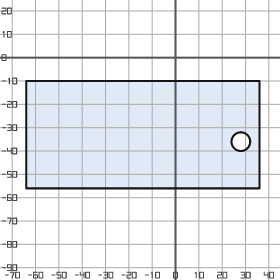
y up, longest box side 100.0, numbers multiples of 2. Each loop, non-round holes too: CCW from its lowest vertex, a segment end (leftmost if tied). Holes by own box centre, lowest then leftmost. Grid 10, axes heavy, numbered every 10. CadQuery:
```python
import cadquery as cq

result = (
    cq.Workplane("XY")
    .moveTo(-64.0, -56.0)
    .lineTo(36.0, -56.0)
    .lineTo(36.0, -10.0)
    .lineTo(-64.0, -10.0)
    .close()
    .moveTo(28.0, -36.0)
    .circle(4.0)
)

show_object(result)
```